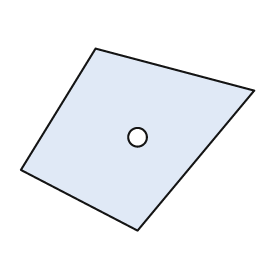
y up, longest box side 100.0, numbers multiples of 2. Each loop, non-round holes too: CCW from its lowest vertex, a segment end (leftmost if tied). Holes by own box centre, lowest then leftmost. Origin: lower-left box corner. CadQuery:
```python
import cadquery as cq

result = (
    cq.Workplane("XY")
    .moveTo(50.0, 0.0)
    .lineTo(100.0, 60.0)
    .lineTo(32.0, 78.0)
    .lineTo(0.0, 26.0)
    .close()
    .moveTo(50.0, 40.0)
    .circle(4.0)
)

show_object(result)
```